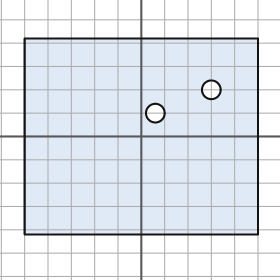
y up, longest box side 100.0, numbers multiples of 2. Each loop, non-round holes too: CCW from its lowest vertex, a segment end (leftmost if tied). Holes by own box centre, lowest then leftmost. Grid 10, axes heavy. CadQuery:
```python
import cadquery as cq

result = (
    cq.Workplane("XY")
    .moveTo(-50.0, -42.0)
    .lineTo(50.0, -42.0)
    .lineTo(50.0, 42.0)
    .lineTo(-50.0, 42.0)
    .close()
    .moveTo(6.0, 10.0)
    .circle(4.0)
    .moveTo(30.0, 20.0)
    .circle(4.0)
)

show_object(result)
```